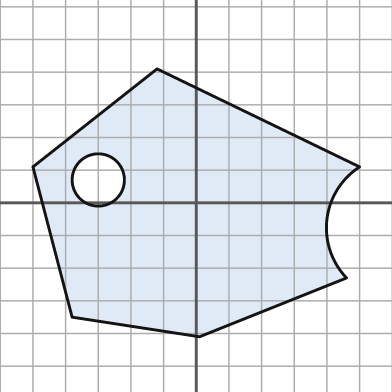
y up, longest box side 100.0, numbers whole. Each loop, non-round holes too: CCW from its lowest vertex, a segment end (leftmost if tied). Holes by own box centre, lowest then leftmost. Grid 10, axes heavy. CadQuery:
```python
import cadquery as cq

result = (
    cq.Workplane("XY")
    .moveTo(1.0, -41.0)
    .lineTo(46.0, -23.0)
    .threePointArc((40.0, -5.0), (50.0, 11.0))
    .lineTo(-12.0, 41.0)
    .lineTo(-50.0, 11.0)
    .lineTo(-38.0, -35.0)
    .close()
    .moveTo(-30.0, 7.0)
    .circle(8.0)
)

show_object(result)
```